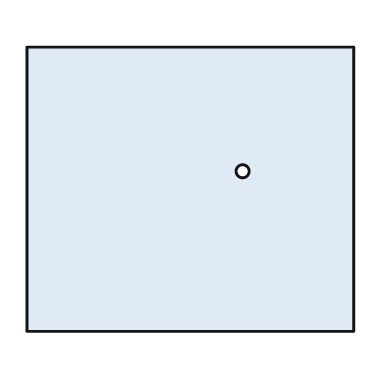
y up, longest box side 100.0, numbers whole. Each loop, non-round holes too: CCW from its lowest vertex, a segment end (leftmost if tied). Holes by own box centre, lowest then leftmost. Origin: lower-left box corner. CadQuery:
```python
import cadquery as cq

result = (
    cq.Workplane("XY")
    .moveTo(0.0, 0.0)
    .lineTo(100.0, 0.0)
    .lineTo(100.0, 87.0)
    .lineTo(0.0, 87.0)
    .close()
    .moveTo(66.0, 49.0)
    .circle(2.0)
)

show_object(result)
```